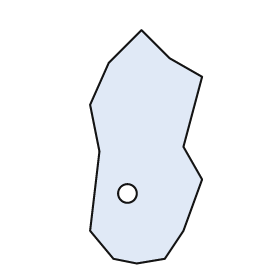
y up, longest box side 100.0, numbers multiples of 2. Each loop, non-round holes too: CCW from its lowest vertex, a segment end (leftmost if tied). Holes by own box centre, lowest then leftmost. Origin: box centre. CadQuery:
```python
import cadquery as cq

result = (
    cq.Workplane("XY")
    .moveTo(-4.0, -50.0)
    .lineTo(8.0, -48.0)
    .lineTo(16.0, -36.0)
    .lineTo(24.0, -14.0)
    .lineTo(16.0, 0.0)
    .lineTo(24.0, 30.0)
    .lineTo(10.0, 38.0)
    .lineTo(-2.0, 50.0)
    .lineTo(-16.0, 36.0)
    .lineTo(-24.0, 18.0)
    .lineTo(-20.0, -2.0)
    .lineTo(-24.0, -36.0)
    .lineTo(-14.0, -48.0)
    .close()
    .moveTo(-8.0, -20.0)
    .circle(4.0)
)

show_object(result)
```